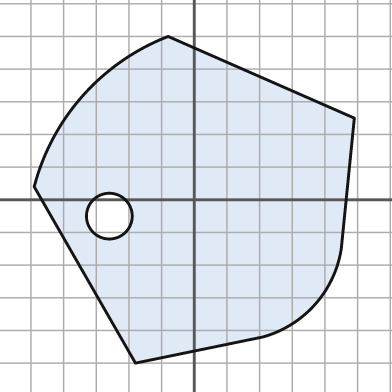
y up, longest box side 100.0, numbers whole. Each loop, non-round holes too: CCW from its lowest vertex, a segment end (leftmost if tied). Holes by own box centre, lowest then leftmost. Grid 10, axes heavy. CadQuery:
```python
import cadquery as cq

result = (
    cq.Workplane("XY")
    .moveTo(-18.0, -50.0)
    .lineTo(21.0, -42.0)
    .threePointArc((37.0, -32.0), (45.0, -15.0))
    .lineTo(49.0, 25.0)
    .lineTo(-8.0, 50.0)
    .threePointArc((-34.0, 32.0), (-49.0, 4.0))
    .close()
    .moveTo(-26.0, -5.0)
    .circle(7.0)
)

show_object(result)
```